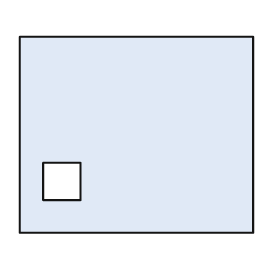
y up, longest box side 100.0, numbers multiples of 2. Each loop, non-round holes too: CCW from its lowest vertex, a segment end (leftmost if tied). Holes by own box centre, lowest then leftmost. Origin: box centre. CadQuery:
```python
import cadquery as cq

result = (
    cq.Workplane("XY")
    .moveTo(-50.0, -42.0)
    .lineTo(50.0, -42.0)
    .lineTo(50.0, 42.0)
    .lineTo(-50.0, 42.0)
    .close()
    .moveTo(-40.0, -28.0)
    .lineTo(-24.0, -28.0)
    .lineTo(-24.0, -12.0)
    .lineTo(-40.0, -12.0)
    .close()
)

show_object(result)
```